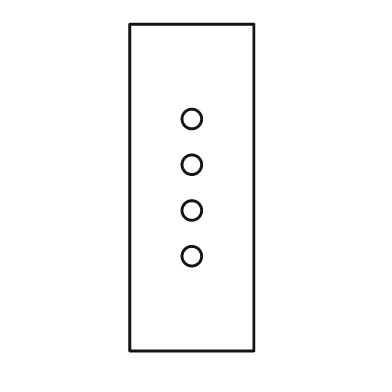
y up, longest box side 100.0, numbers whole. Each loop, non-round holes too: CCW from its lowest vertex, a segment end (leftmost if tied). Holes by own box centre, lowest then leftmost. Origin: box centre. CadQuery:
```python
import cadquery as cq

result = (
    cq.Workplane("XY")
    .moveTo(-19.0, -50.0)
    .lineTo(19.0, -50.0)
    .lineTo(19.0, 50.0)
    .lineTo(-19.0, 50.0)
    .close()
    .moveTo(0.0, -21.0)
    .circle(3.0)
    .moveTo(0.0, -7.0)
    .circle(3.0)
    .moveTo(0.0, 7.0)
    .circle(3.0)
    .moveTo(0.0, 21.0)
    .circle(3.0)
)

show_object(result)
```